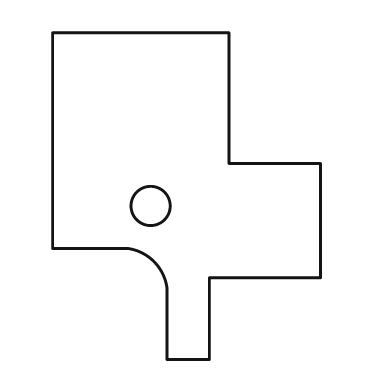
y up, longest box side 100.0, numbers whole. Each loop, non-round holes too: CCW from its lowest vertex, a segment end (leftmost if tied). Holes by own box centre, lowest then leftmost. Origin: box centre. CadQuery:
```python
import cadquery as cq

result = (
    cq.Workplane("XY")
    .moveTo(-6.0, -50.0)
    .lineTo(7.0, -50.0)
    .lineTo(7.0, -25.0)
    .lineTo(41.0, -25.0)
    .lineTo(41.0, 10.0)
    .lineTo(13.0, 10.0)
    .lineTo(13.0, 50.0)
    .lineTo(-41.0, 50.0)
    .lineTo(-41.0, -16.0)
    .lineTo(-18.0, -16.0)
    .threePointArc((-10.0, -20.0), (-6.0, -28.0))
    .close()
    .moveTo(-11.0, -3.0)
    .circle(6.0)
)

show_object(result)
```